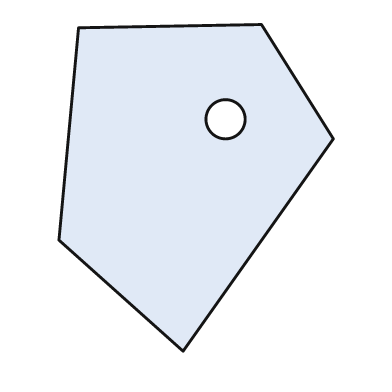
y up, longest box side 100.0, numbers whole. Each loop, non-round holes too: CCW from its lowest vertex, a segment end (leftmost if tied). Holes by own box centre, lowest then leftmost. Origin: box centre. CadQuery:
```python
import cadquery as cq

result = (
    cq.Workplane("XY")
    .moveTo(-4.0, -50.0)
    .lineTo(42.0, 15.0)
    .lineTo(20.0, 50.0)
    .lineTo(-36.0, 49.0)
    .lineTo(-42.0, -16.0)
    .close()
    .moveTo(9.0, 21.0)
    .circle(6.0)
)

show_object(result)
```